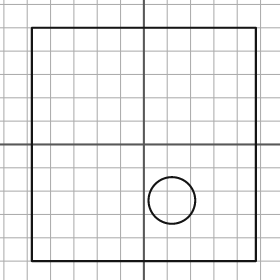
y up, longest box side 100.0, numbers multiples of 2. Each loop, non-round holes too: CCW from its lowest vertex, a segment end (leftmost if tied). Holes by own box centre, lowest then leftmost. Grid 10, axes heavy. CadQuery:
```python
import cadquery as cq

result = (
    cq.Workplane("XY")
    .moveTo(-48.0, -50.0)
    .lineTo(48.0, -50.0)
    .lineTo(48.0, 50.0)
    .lineTo(-48.0, 50.0)
    .close()
    .moveTo(12.0, -24.0)
    .circle(10.0)
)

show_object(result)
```